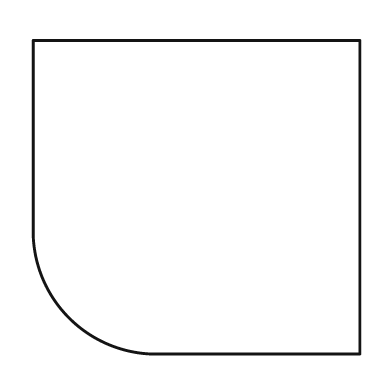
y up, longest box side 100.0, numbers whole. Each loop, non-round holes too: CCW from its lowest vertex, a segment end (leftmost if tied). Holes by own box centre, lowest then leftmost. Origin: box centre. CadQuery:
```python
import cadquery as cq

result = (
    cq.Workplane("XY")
    .moveTo(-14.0, -48.0)
    .lineTo(50.0, -48.0)
    .lineTo(50.0, 48.0)
    .lineTo(-50.0, 48.0)
    .lineTo(-50.0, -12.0)
    .threePointArc((-39.0, -37.0), (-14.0, -48.0))
    .close()
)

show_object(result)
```